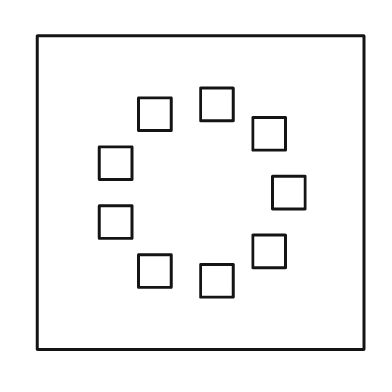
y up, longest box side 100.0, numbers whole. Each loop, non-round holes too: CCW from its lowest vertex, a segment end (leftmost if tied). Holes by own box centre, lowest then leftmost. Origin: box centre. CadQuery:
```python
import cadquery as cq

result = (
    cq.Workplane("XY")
    .moveTo(-50.0, -48.0)
    .lineTo(50.0, -48.0)
    .lineTo(50.0, 48.0)
    .lineTo(-50.0, 48.0)
    .close()
    .moveTo(0.0, -32.0)
    .lineTo(10.0, -32.0)
    .lineTo(10.0, -22.0)
    .lineTo(0.0, -22.0)
    .close()
    .moveTo(-19.0, -29.0)
    .lineTo(-9.0, -29.0)
    .lineTo(-9.0, -19.0)
    .lineTo(-19.0, -19.0)
    .close()
    .moveTo(16.0, -23.0)
    .lineTo(26.0, -23.0)
    .lineTo(26.0, -13.0)
    .lineTo(16.0, -13.0)
    .close()
    .moveTo(-31.0, -14.0)
    .lineTo(-21.0, -14.0)
    .lineTo(-21.0, -4.0)
    .lineTo(-31.0, -4.0)
    .close()
    .moveTo(22.0, -5.0)
    .lineTo(32.0, -5.0)
    .lineTo(32.0, 5.0)
    .lineTo(22.0, 5.0)
    .close()
    .moveTo(-31.0, 4.0)
    .lineTo(-21.0, 4.0)
    .lineTo(-21.0, 14.0)
    .lineTo(-31.0, 14.0)
    .close()
    .moveTo(16.0, 13.0)
    .lineTo(26.0, 13.0)
    .lineTo(26.0, 23.0)
    .lineTo(16.0, 23.0)
    .close()
    .moveTo(-19.0, 19.0)
    .lineTo(-9.0, 19.0)
    .lineTo(-9.0, 29.0)
    .lineTo(-19.0, 29.0)
    .close()
    .moveTo(0.0, 22.0)
    .lineTo(10.0, 22.0)
    .lineTo(10.0, 32.0)
    .lineTo(0.0, 32.0)
    .close()
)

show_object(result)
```